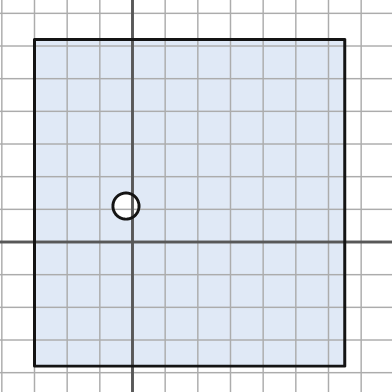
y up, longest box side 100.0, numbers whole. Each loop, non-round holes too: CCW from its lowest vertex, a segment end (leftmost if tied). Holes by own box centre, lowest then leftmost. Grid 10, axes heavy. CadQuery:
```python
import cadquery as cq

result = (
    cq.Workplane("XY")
    .moveTo(-30.0, -38.0)
    .lineTo(65.0, -38.0)
    .lineTo(65.0, 62.0)
    .lineTo(-30.0, 62.0)
    .close()
    .moveTo(-2.0, 11.0)
    .circle(4.0)
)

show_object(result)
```